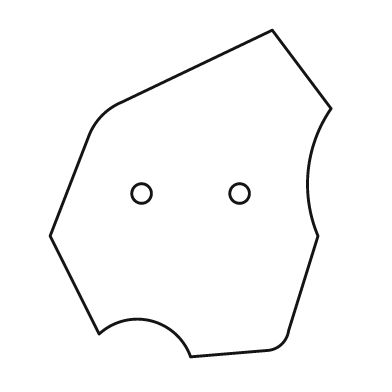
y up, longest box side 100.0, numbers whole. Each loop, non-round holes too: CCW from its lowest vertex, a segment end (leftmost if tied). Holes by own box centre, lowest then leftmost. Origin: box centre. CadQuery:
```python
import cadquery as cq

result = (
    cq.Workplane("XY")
    .moveTo(0.0, -50.0)
    .lineTo(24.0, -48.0)
    .threePointArc((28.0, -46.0), (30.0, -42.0))
    .lineTo(39.0, -13.0)
    .threePointArc((36.0, 7.0), (43.0, 26.0))
    .lineTo(25.0, 50.0)
    .lineTo(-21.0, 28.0)
    .threePointArc((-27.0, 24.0), (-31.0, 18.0))
    .lineTo(-43.0, -13.0)
    .lineTo(-28.0, -43.0)
    .threePointArc((-12.0, -39.0), (0.0, -50.0))
    .close()
    .moveTo(-15.0, 0.0)
    .circle(3.0)
    .moveTo(15.0, 0.0)
    .circle(3.0)
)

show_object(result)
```